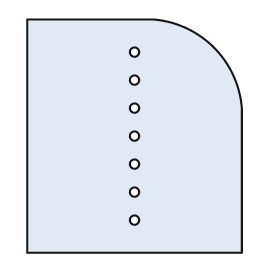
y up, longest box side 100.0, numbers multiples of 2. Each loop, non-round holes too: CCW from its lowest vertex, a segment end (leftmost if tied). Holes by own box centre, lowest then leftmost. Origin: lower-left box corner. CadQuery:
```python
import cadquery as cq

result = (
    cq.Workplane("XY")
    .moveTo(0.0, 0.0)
    .lineTo(92.0, 0.0)
    .lineTo(92.0, 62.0)
    .threePointArc((80.0, 88.0), (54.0, 100.0))
    .lineTo(0.0, 100.0)
    .close()
    .moveTo(46.0, 14.0)
    .circle(2.0)
    .moveTo(46.0, 26.0)
    .circle(2.0)
    .moveTo(46.0, 38.0)
    .circle(2.0)
    .moveTo(46.0, 50.0)
    .circle(2.0)
    .moveTo(46.0, 62.0)
    .circle(2.0)
    .moveTo(46.0, 74.0)
    .circle(2.0)
    .moveTo(46.0, 86.0)
    .circle(2.0)
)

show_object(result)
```